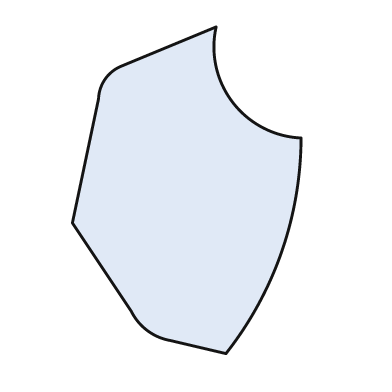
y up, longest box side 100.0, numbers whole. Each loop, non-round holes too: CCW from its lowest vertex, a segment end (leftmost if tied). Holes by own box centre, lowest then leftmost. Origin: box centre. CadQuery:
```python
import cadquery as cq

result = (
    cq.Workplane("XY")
    .moveTo(12.0, -50.0)
    .threePointArc((29.0, -19.0), (35.0, 16.0))
    .threePointArc((14.0, 27.0), (9.0, 50.0))
    .lineTo(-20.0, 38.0)
    .threePointArc((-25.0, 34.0), (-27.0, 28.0))
    .lineTo(-35.0, -10.0)
    .lineTo(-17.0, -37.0)
    .threePointArc((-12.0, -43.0), (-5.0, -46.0))
    .close()
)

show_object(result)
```